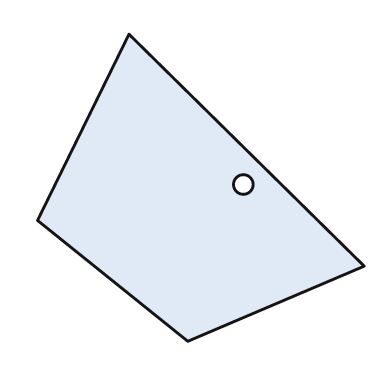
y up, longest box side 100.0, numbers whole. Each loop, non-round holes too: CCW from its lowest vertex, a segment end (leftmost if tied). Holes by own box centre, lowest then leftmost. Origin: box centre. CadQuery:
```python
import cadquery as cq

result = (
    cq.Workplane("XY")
    .moveTo(-4.0, -47.0)
    .lineTo(50.0, -24.0)
    .lineTo(-22.0, 47.0)
    .lineTo(-50.0, -10.0)
    .close()
    .moveTo(13.0, 1.0)
    .circle(3.0)
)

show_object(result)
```